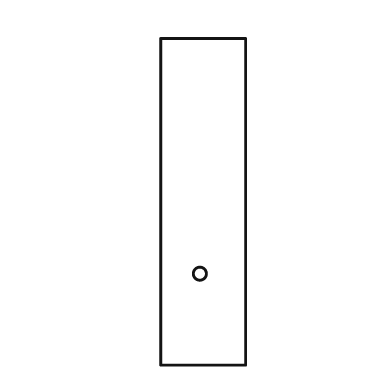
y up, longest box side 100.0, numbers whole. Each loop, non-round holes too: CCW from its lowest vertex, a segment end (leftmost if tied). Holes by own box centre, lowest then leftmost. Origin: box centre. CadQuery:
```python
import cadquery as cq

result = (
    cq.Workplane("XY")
    .moveTo(-13.0, -50.0)
    .lineTo(13.0, -50.0)
    .lineTo(13.0, 50.0)
    .lineTo(-13.0, 50.0)
    .close()
    .moveTo(-1.0, -22.0)
    .circle(2.0)
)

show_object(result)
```